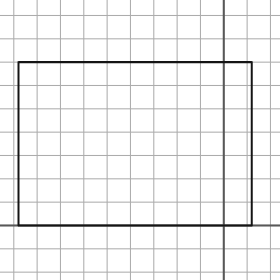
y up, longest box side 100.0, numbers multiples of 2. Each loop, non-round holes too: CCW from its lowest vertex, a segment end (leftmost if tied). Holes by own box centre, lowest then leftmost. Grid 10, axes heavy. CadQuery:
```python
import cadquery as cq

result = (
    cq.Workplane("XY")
    .moveTo(-88.0, 0.0)
    .lineTo(12.0, 0.0)
    .lineTo(12.0, 70.0)
    .lineTo(-88.0, 70.0)
    .close()
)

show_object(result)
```